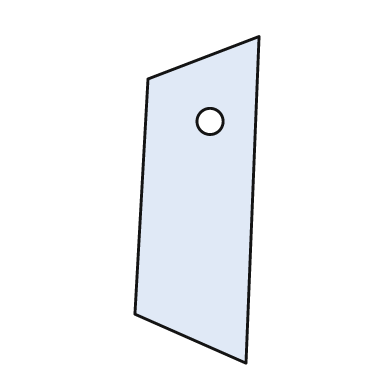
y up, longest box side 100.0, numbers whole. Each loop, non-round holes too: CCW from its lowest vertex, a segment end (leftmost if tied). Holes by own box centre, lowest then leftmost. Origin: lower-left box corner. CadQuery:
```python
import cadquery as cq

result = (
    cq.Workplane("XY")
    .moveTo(34.0, 0.0)
    .lineTo(38.0, 100.0)
    .lineTo(4.0, 87.0)
    .lineTo(0.0, 15.0)
    .close()
    .moveTo(23.0, 74.0)
    .circle(4.0)
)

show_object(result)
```